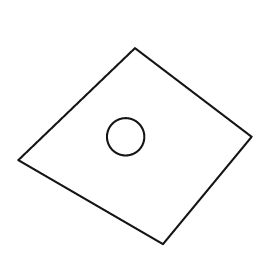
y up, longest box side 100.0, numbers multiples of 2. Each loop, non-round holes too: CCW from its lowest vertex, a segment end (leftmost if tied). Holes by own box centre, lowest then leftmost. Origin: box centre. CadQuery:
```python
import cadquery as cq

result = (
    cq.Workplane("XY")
    .moveTo(12.0, -42.0)
    .lineTo(50.0, 4.0)
    .lineTo(0.0, 42.0)
    .lineTo(-50.0, -6.0)
    .close()
    .moveTo(-4.0, 4.0)
    .circle(8.0)
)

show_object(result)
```